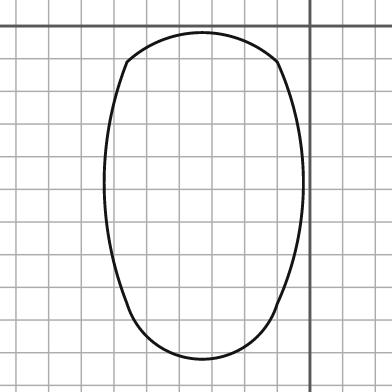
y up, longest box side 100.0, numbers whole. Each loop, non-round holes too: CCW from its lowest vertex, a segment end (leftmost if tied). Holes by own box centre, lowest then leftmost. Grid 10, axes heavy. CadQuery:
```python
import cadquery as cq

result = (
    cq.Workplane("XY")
    .moveTo(-56.0, -85.0)
    .threePointArc((-33.0, -102.0), (-10.0, -85.0))
    .threePointArc((-2.0, -48.0), (-10.0, -11.0))
    .threePointArc((-33.0, -2.0), (-56.0, -11.0))
    .threePointArc((-63.0, -48.0), (-56.0, -85.0))
    .close()
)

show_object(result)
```